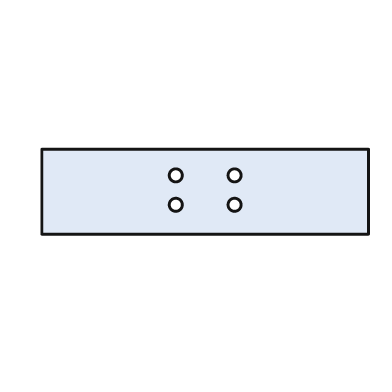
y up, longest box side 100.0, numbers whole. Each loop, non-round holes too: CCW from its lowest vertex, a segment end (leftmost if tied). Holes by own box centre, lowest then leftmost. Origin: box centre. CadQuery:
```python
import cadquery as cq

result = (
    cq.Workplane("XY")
    .moveTo(-50.0, -13.0)
    .lineTo(50.0, -13.0)
    .lineTo(50.0, 13.0)
    .lineTo(-50.0, 13.0)
    .close()
    .moveTo(-9.0, -4.0)
    .circle(2.0)
    .moveTo(9.0, -4.0)
    .circle(2.0)
    .moveTo(-9.0, 5.0)
    .circle(2.0)
    .moveTo(9.0, 5.0)
    .circle(2.0)
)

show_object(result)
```